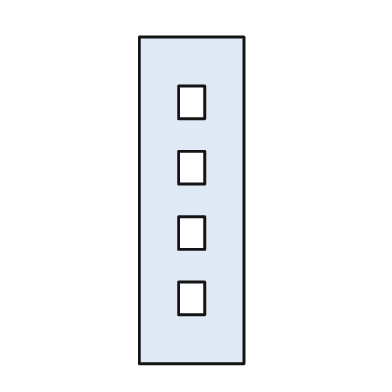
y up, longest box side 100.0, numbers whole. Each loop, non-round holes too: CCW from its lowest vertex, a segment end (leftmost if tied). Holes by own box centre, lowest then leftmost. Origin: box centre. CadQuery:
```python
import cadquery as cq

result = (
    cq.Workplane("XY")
    .moveTo(-16.0, -50.0)
    .lineTo(16.0, -50.0)
    .lineTo(16.0, 50.0)
    .lineTo(-16.0, 50.0)
    .close()
    .moveTo(-4.0, -35.0)
    .lineTo(4.0, -35.0)
    .lineTo(4.0, -25.0)
    .lineTo(-4.0, -25.0)
    .close()
    .moveTo(-4.0, -15.0)
    .lineTo(4.0, -15.0)
    .lineTo(4.0, -5.0)
    .lineTo(-4.0, -5.0)
    .close()
    .moveTo(-4.0, 5.0)
    .lineTo(4.0, 5.0)
    .lineTo(4.0, 15.0)
    .lineTo(-4.0, 15.0)
    .close()
    .moveTo(-4.0, 25.0)
    .lineTo(4.0, 25.0)
    .lineTo(4.0, 35.0)
    .lineTo(-4.0, 35.0)
    .close()
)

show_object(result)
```